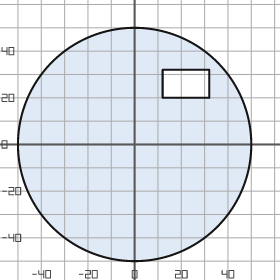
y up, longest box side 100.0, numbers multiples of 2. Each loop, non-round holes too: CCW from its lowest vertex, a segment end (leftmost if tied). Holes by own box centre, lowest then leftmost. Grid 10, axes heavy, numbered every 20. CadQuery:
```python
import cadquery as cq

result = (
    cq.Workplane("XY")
    .moveTo(0.0, 0.0)
    .circle(50.0)
    .moveTo(12.0, 20.0)
    .lineTo(32.0, 20.0)
    .lineTo(32.0, 32.0)
    .lineTo(12.0, 32.0)
    .close()
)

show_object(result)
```